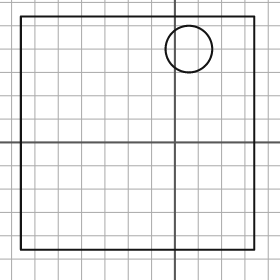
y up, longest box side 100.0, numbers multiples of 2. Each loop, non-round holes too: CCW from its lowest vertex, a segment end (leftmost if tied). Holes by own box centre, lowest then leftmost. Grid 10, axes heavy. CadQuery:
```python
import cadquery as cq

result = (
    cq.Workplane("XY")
    .moveTo(-66.0, -46.0)
    .lineTo(34.0, -46.0)
    .lineTo(34.0, 54.0)
    .lineTo(-66.0, 54.0)
    .close()
    .moveTo(6.0, 40.0)
    .circle(10.0)
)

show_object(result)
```